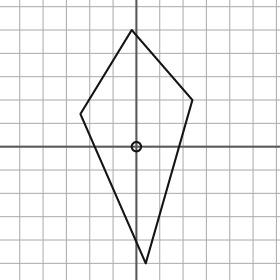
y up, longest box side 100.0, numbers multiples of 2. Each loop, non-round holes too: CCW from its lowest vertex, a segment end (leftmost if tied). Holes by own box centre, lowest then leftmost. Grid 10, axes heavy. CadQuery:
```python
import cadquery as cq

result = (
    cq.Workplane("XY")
    .moveTo(4.0, -50.0)
    .lineTo(24.0, 20.0)
    .lineTo(-2.0, 50.0)
    .lineTo(-24.0, 14.0)
    .close()
    .moveTo(0.0, 0.0)
    .circle(2.0)
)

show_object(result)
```